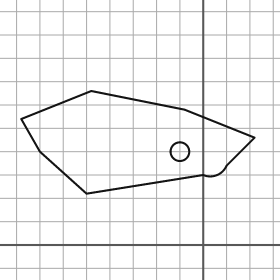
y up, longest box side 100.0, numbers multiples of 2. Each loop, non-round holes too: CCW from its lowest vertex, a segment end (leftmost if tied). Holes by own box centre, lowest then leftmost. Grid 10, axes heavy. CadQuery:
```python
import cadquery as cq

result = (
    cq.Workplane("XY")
    .moveTo(-50.0, 22.0)
    .lineTo(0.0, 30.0)
    .threePointArc((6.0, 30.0), (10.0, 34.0))
    .lineTo(22.0, 46.0)
    .lineTo(-8.0, 58.0)
    .lineTo(-48.0, 66.0)
    .lineTo(-78.0, 54.0)
    .lineTo(-70.0, 40.0)
    .close()
    .moveTo(-10.0, 40.0)
    .circle(4.0)
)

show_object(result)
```